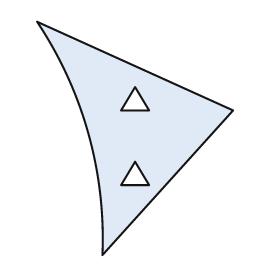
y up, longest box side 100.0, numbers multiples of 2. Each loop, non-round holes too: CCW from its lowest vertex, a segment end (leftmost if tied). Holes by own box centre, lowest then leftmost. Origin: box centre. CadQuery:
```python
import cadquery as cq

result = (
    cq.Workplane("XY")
    .moveTo(-14.0, -50.0)
    .lineTo(42.0, 12.0)
    .lineTo(-42.0, 50.0)
    .threePointArc((-20.0, 2.0), (-14.0, -50.0))
    .close()
    .moveTo(-6.0, -20.0)
    .lineTo(6.0, -20.0)
    .lineTo(0.0, -10.0)
    .close()
    .moveTo(-6.0, 12.0)
    .lineTo(6.0, 12.0)
    .lineTo(0.0, 22.0)
    .close()
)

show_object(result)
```